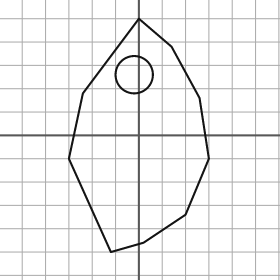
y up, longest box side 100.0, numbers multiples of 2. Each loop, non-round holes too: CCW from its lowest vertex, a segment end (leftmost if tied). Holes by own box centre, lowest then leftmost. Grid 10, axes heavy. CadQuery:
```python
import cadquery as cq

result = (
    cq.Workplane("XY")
    .moveTo(-12.0, -50.0)
    .lineTo(2.0, -46.0)
    .lineTo(20.0, -34.0)
    .lineTo(30.0, -10.0)
    .lineTo(26.0, 16.0)
    .lineTo(14.0, 38.0)
    .lineTo(0.0, 50.0)
    .lineTo(-24.0, 18.0)
    .lineTo(-30.0, -10.0)
    .close()
    .moveTo(-2.0, 26.0)
    .circle(8.0)
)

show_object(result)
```